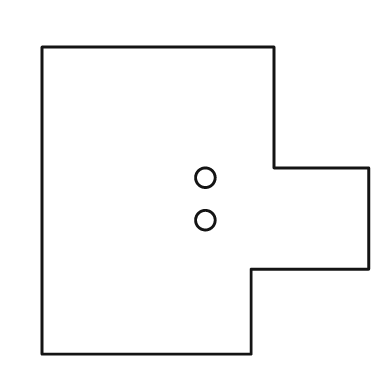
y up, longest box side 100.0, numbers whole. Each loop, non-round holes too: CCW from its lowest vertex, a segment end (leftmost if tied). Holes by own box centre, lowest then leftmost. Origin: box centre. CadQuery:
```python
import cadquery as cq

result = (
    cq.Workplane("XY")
    .moveTo(-50.0, -47.0)
    .lineTo(14.0, -47.0)
    .lineTo(14.0, -21.0)
    .lineTo(50.0, -21.0)
    .lineTo(50.0, 10.0)
    .lineTo(21.0, 10.0)
    .lineTo(21.0, 47.0)
    .lineTo(-50.0, 47.0)
    .close()
    .moveTo(0.0, -6.0)
    .circle(3.0)
    .moveTo(0.0, 7.0)
    .circle(3.0)
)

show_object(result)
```